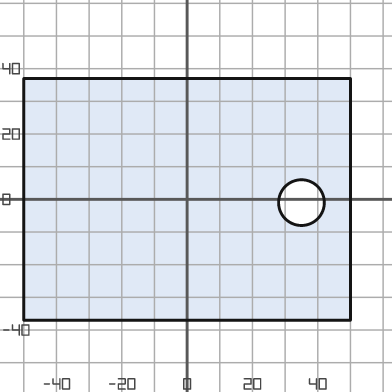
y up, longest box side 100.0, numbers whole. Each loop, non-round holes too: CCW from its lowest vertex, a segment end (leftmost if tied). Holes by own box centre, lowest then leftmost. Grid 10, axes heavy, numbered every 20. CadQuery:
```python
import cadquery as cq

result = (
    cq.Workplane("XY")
    .moveTo(-50.0, -37.0)
    .lineTo(50.0, -37.0)
    .lineTo(50.0, 37.0)
    .lineTo(-50.0, 37.0)
    .close()
    .moveTo(35.0, -1.0)
    .circle(7.0)
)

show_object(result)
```